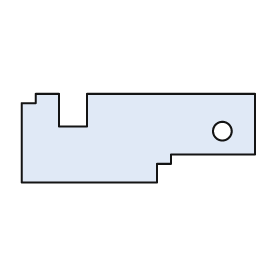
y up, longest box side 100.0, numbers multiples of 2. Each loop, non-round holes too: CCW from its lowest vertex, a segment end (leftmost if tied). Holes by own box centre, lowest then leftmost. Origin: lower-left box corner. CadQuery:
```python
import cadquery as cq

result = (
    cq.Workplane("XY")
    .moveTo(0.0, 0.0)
    .lineTo(58.0, 0.0)
    .lineTo(58.0, 8.0)
    .lineTo(64.0, 8.0)
    .lineTo(64.0, 12.0)
    .lineTo(100.0, 12.0)
    .lineTo(100.0, 38.0)
    .lineTo(28.0, 38.0)
    .lineTo(28.0, 24.0)
    .lineTo(16.0, 24.0)
    .lineTo(16.0, 38.0)
    .lineTo(6.0, 38.0)
    .lineTo(6.0, 34.0)
    .lineTo(0.0, 34.0)
    .close()
    .moveTo(86.0, 22.0)
    .circle(4.0)
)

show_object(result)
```